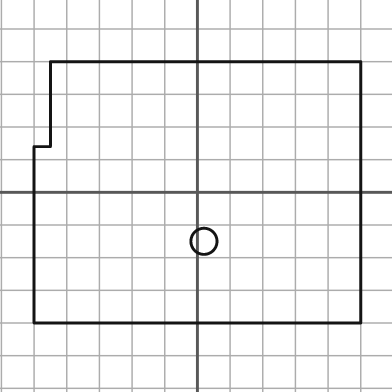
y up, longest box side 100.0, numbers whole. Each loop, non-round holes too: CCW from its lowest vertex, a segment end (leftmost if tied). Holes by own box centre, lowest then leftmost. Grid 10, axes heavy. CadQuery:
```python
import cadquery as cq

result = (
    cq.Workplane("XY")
    .moveTo(-50.0, -40.0)
    .lineTo(50.0, -40.0)
    .lineTo(50.0, 40.0)
    .lineTo(-45.0, 40.0)
    .lineTo(-45.0, 14.0)
    .lineTo(-50.0, 14.0)
    .close()
    .moveTo(2.0, -15.0)
    .circle(4.0)
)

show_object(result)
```